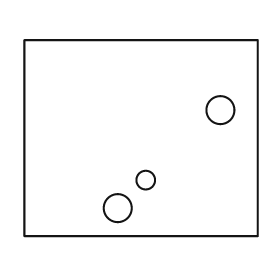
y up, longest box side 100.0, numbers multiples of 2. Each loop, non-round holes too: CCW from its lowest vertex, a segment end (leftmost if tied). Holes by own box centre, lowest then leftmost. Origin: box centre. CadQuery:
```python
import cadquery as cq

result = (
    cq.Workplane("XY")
    .moveTo(-50.0, -42.0)
    .lineTo(50.0, -42.0)
    .lineTo(50.0, 42.0)
    .lineTo(-50.0, 42.0)
    .close()
    .moveTo(-10.0, -30.0)
    .circle(6.0)
    .moveTo(2.0, -18.0)
    .circle(4.0)
    .moveTo(34.0, 12.0)
    .circle(6.0)
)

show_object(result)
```